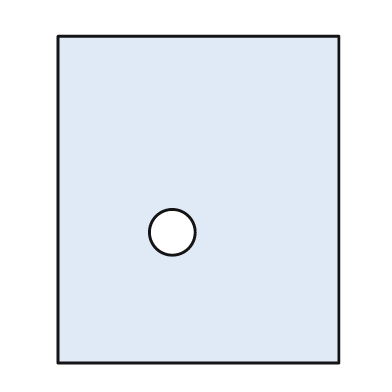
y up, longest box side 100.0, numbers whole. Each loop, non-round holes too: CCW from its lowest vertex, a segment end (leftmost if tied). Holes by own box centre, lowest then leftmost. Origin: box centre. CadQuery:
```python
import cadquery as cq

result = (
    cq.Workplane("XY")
    .moveTo(-43.0, -50.0)
    .lineTo(43.0, -50.0)
    .lineTo(43.0, 50.0)
    .lineTo(-43.0, 50.0)
    .close()
    .moveTo(-8.0, -10.0)
    .circle(7.0)
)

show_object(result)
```